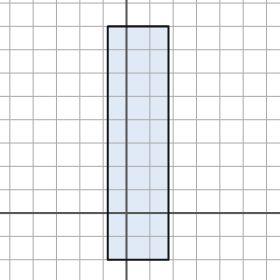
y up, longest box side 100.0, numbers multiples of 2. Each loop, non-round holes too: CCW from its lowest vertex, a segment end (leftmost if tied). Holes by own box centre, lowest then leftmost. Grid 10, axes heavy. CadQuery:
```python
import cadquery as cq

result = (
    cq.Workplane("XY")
    .moveTo(-8.0, -20.0)
    .lineTo(18.0, -20.0)
    .lineTo(18.0, 80.0)
    .lineTo(-8.0, 80.0)
    .close()
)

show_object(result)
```